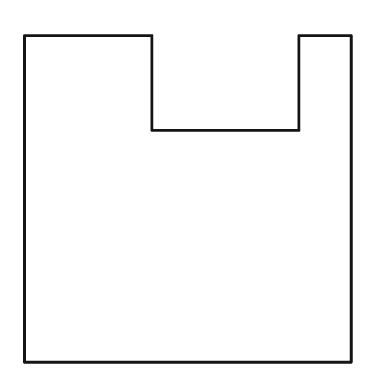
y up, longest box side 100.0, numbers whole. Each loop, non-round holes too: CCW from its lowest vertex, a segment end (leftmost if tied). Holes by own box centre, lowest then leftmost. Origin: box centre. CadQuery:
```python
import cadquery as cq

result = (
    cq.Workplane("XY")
    .moveTo(-50.0, -50.0)
    .lineTo(50.0, -50.0)
    .lineTo(50.0, 50.0)
    .lineTo(34.0, 50.0)
    .lineTo(34.0, 21.0)
    .lineTo(-11.0, 21.0)
    .lineTo(-11.0, 50.0)
    .lineTo(-50.0, 50.0)
    .close()
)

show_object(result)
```